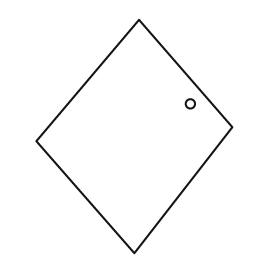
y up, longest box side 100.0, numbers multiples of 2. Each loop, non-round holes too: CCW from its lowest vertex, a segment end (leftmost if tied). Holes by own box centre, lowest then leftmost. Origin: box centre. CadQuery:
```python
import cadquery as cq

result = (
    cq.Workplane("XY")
    .moveTo(0.0, -50.0)
    .lineTo(42.0, 4.0)
    .lineTo(2.0, 50.0)
    .lineTo(-42.0, -2.0)
    .close()
    .moveTo(24.0, 14.0)
    .circle(2.0)
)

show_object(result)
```